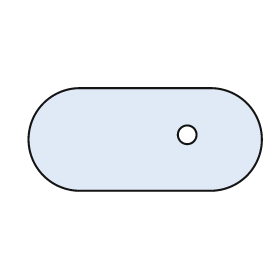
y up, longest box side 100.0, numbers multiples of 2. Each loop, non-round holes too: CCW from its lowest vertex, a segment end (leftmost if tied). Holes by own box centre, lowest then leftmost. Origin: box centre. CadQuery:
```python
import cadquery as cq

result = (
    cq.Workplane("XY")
    .moveTo(-28.0, -22.0)
    .lineTo(28.0, -22.0)
    .threePointArc((50.0, 0.0), (28.0, 22.0))
    .lineTo(-28.0, 22.0)
    .threePointArc((-50.0, 0.0), (-28.0, -22.0))
    .close()
    .moveTo(18.0, 2.0)
    .circle(4.0)
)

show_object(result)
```